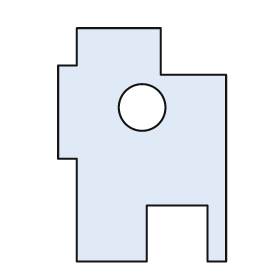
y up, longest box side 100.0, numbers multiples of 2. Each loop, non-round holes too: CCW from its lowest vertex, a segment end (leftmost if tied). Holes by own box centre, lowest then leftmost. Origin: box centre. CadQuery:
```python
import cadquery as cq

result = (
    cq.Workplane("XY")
    .moveTo(-28.0, -50.0)
    .lineTo(2.0, -50.0)
    .lineTo(2.0, -26.0)
    .lineTo(28.0, -26.0)
    .lineTo(28.0, -50.0)
    .lineTo(36.0, -50.0)
    .lineTo(36.0, 30.0)
    .lineTo(8.0, 30.0)
    .lineTo(8.0, 50.0)
    .lineTo(-28.0, 50.0)
    .lineTo(-28.0, 34.0)
    .lineTo(-36.0, 34.0)
    .lineTo(-36.0, -6.0)
    .lineTo(-28.0, -6.0)
    .close()
    .moveTo(0.0, 16.0)
    .circle(10.0)
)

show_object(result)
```